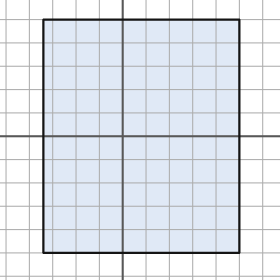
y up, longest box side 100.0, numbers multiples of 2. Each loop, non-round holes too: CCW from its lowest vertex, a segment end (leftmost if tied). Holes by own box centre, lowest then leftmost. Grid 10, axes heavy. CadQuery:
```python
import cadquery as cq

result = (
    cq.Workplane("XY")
    .moveTo(-34.0, -50.0)
    .lineTo(50.0, -50.0)
    .lineTo(50.0, 50.0)
    .lineTo(-34.0, 50.0)
    .close()
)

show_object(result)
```